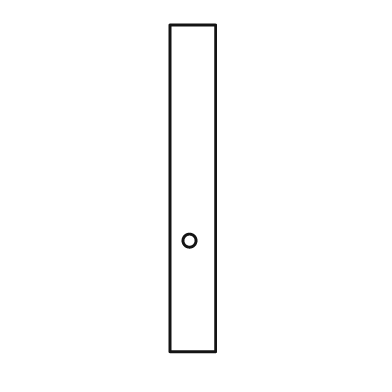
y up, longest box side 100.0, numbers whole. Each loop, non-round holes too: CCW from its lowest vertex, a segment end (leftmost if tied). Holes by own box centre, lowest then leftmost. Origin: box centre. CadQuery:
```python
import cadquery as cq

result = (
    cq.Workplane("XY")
    .moveTo(-7.0, -50.0)
    .lineTo(7.0, -50.0)
    .lineTo(7.0, 50.0)
    .lineTo(-7.0, 50.0)
    .close()
    .moveTo(-1.0, -16.0)
    .circle(2.0)
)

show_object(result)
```